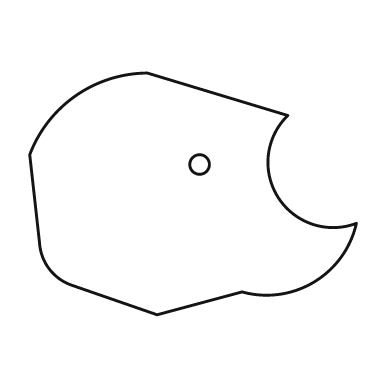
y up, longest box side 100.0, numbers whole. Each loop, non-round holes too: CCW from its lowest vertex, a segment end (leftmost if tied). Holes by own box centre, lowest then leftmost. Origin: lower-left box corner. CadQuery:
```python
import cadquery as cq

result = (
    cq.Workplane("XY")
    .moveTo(39.0, 0.0)
    .lineTo(65.0, 7.0)
    .threePointArc((87.0, 10.0), (100.0, 28.0))
    .threePointArc((76.0, 36.0), (79.0, 61.0))
    .lineTo(36.0, 74.0)
    .threePointArc((14.0, 67.0), (0.0, 49.0))
    .lineTo(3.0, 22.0)
    .threePointArc((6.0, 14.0), (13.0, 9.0))
    .close()
    .moveTo(52.0, 46.0)
    .circle(3.0)
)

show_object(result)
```